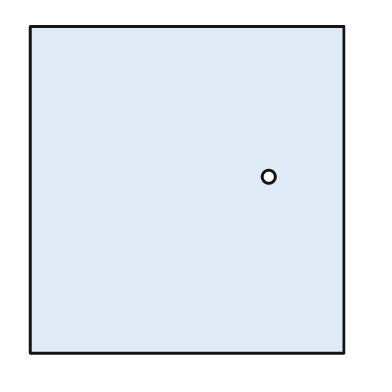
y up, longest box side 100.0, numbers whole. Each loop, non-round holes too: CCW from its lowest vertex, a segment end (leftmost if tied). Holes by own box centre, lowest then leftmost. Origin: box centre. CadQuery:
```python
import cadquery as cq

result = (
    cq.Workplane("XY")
    .moveTo(-48.0, -50.0)
    .lineTo(48.0, -50.0)
    .lineTo(48.0, 50.0)
    .lineTo(-48.0, 50.0)
    .close()
    .moveTo(25.0, 4.0)
    .circle(2.0)
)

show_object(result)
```